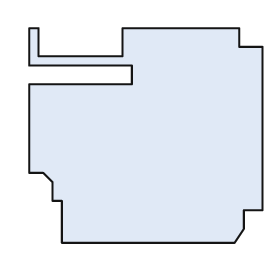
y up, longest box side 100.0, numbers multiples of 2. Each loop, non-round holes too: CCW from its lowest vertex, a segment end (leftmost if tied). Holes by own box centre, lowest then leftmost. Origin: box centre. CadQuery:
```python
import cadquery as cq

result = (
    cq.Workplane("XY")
    .moveTo(-36.0, -46.0)
    .lineTo(38.0, -46.0)
    .lineTo(42.0, -40.0)
    .lineTo(42.0, -32.0)
    .lineTo(50.0, -32.0)
    .lineTo(50.0, 38.0)
    .lineTo(40.0, 38.0)
    .lineTo(40.0, 46.0)
    .lineTo(-10.0, 46.0)
    .lineTo(-10.0, 34.0)
    .lineTo(-46.0, 34.0)
    .lineTo(-46.0, 46.0)
    .lineTo(-50.0, 46.0)
    .lineTo(-50.0, 30.0)
    .lineTo(-6.0, 30.0)
    .lineTo(-6.0, 22.0)
    .lineTo(-50.0, 22.0)
    .lineTo(-50.0, -16.0)
    .lineTo(-44.0, -16.0)
    .lineTo(-40.0, -20.0)
    .lineTo(-40.0, -28.0)
    .lineTo(-36.0, -28.0)
    .close()
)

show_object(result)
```